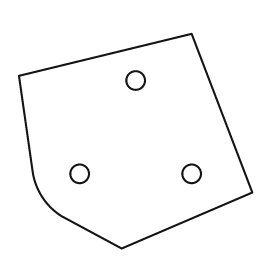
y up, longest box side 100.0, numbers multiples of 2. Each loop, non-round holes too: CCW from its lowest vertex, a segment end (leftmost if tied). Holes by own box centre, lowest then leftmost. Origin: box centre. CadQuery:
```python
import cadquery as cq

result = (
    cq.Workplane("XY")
    .moveTo(-6.0, -46.0)
    .lineTo(50.0, -22.0)
    .lineTo(24.0, 46.0)
    .lineTo(-50.0, 28.0)
    .lineTo(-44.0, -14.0)
    .threePointArc((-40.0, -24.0), (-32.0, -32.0))
    .close()
    .moveTo(-24.0, -14.0)
    .circle(4.0)
    .moveTo(24.0, -14.0)
    .circle(4.0)
    .moveTo(0.0, 26.0)
    .circle(4.0)
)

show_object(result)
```